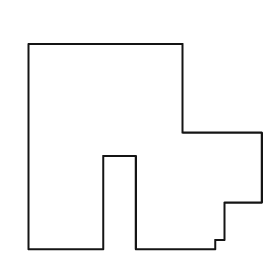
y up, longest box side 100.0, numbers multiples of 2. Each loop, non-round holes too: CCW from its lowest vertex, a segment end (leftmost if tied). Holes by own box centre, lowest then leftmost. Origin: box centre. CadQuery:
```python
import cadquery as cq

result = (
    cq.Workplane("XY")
    .moveTo(-50.0, -44.0)
    .lineTo(-18.0, -44.0)
    .lineTo(-18.0, -4.0)
    .lineTo(-4.0, -4.0)
    .lineTo(-4.0, -44.0)
    .lineTo(30.0, -44.0)
    .lineTo(30.0, -40.0)
    .lineTo(34.0, -40.0)
    .lineTo(34.0, -24.0)
    .lineTo(50.0, -24.0)
    .lineTo(50.0, 6.0)
    .lineTo(16.0, 6.0)
    .lineTo(16.0, 44.0)
    .lineTo(-50.0, 44.0)
    .close()
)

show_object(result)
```